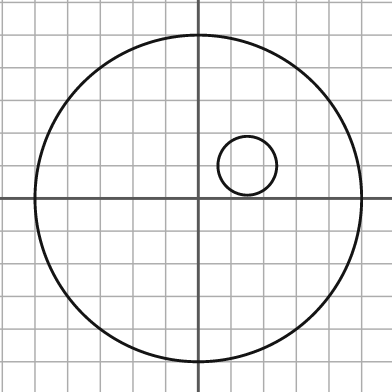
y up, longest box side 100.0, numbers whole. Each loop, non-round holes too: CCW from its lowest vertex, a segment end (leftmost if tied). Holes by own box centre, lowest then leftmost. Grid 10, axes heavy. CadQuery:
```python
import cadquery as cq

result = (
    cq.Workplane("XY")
    .moveTo(0.0, 0.0)
    .circle(50.0)
    .moveTo(15.0, 10.0)
    .circle(9.0)
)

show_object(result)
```